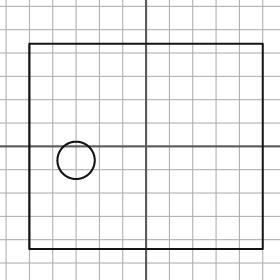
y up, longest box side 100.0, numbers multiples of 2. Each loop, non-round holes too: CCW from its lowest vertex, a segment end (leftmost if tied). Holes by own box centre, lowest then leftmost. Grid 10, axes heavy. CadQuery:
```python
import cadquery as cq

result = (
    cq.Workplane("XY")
    .moveTo(-50.0, -44.0)
    .lineTo(50.0, -44.0)
    .lineTo(50.0, 44.0)
    .lineTo(-50.0, 44.0)
    .close()
    .moveTo(-30.0, -6.0)
    .circle(8.0)
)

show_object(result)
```